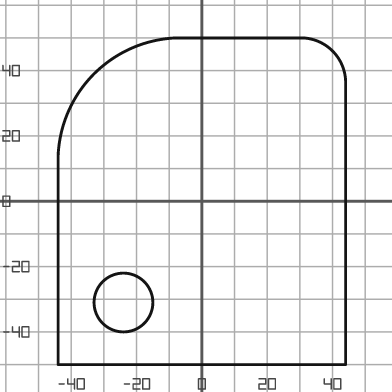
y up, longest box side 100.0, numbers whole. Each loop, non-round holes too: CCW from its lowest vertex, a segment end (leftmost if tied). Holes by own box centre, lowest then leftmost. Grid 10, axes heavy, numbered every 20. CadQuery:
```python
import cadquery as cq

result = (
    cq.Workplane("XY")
    .moveTo(-44.0, -50.0)
    .lineTo(44.0, -50.0)
    .lineTo(44.0, 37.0)
    .threePointArc((40.0, 46.0), (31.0, 50.0))
    .lineTo(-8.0, 50.0)
    .threePointArc((-33.0, 39.0), (-44.0, 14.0))
    .close()
    .moveTo(-24.0, -31.0)
    .circle(9.0)
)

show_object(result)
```